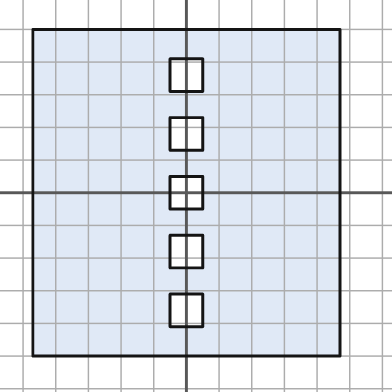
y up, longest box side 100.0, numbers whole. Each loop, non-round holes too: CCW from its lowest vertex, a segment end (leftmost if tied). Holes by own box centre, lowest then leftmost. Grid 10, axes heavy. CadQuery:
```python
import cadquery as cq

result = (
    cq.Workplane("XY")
    .moveTo(-47.0, -50.0)
    .lineTo(47.0, -50.0)
    .lineTo(47.0, 50.0)
    .lineTo(-47.0, 50.0)
    .close()
    .moveTo(-5.0, -41.0)
    .lineTo(5.0, -41.0)
    .lineTo(5.0, -31.0)
    .lineTo(-5.0, -31.0)
    .close()
    .moveTo(-5.0, -23.0)
    .lineTo(5.0, -23.0)
    .lineTo(5.0, -13.0)
    .lineTo(-5.0, -13.0)
    .close()
    .moveTo(-5.0, -5.0)
    .lineTo(5.0, -5.0)
    .lineTo(5.0, 5.0)
    .lineTo(-5.0, 5.0)
    .close()
    .moveTo(-5.0, 13.0)
    .lineTo(5.0, 13.0)
    .lineTo(5.0, 23.0)
    .lineTo(-5.0, 23.0)
    .close()
    .moveTo(-5.0, 31.0)
    .lineTo(5.0, 31.0)
    .lineTo(5.0, 41.0)
    .lineTo(-5.0, 41.0)
    .close()
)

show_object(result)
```